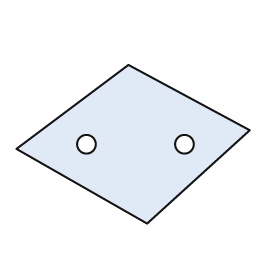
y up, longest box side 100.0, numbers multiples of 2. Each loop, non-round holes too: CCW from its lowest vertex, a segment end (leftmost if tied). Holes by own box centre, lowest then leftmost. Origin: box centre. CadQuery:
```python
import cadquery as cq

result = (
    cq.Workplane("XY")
    .moveTo(6.0, -34.0)
    .lineTo(50.0, 6.0)
    .lineTo(-2.0, 34.0)
    .lineTo(-50.0, -2.0)
    .close()
    .moveTo(-20.0, 0.0)
    .circle(4.0)
    .moveTo(22.0, 0.0)
    .circle(4.0)
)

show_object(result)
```